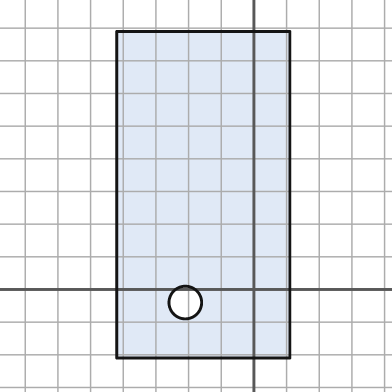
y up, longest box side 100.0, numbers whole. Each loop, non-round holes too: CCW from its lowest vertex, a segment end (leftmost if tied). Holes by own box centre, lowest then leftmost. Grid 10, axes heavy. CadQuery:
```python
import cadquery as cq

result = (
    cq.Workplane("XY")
    .moveTo(-42.0, -21.0)
    .lineTo(11.0, -21.0)
    .lineTo(11.0, 79.0)
    .lineTo(-42.0, 79.0)
    .close()
    .moveTo(-21.0, -4.0)
    .circle(5.0)
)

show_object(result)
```